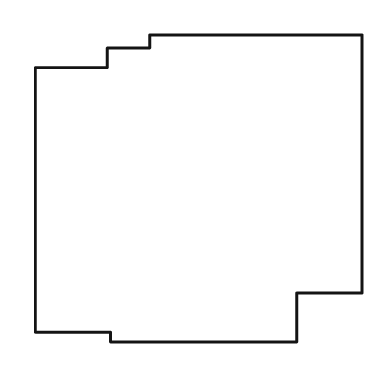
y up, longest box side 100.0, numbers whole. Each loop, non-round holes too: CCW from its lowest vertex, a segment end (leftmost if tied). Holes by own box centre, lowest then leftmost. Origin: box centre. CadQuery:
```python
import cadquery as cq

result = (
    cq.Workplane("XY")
    .moveTo(-27.0, -47.0)
    .lineTo(30.0, -47.0)
    .lineTo(30.0, -32.0)
    .lineTo(50.0, -32.0)
    .lineTo(50.0, 47.0)
    .lineTo(-15.0, 47.0)
    .lineTo(-15.0, 43.0)
    .lineTo(-28.0, 43.0)
    .lineTo(-28.0, 37.0)
    .lineTo(-50.0, 37.0)
    .lineTo(-50.0, -44.0)
    .lineTo(-27.0, -44.0)
    .close()
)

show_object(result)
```